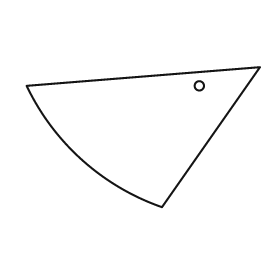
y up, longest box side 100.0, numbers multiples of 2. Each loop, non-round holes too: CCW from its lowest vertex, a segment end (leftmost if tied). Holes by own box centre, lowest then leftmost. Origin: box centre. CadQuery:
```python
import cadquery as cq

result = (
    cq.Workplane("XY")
    .moveTo(8.0, -30.0)
    .lineTo(50.0, 30.0)
    .lineTo(-50.0, 22.0)
    .threePointArc((-26.0, -10.0), (8.0, -30.0))
    .close()
    .moveTo(24.0, 22.0)
    .circle(2.0)
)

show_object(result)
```